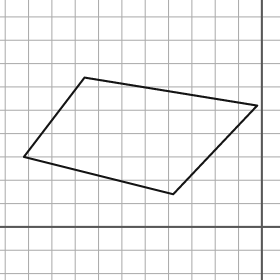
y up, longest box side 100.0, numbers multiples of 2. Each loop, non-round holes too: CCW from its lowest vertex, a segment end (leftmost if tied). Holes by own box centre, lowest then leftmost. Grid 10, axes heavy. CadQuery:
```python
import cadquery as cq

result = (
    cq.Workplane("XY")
    .moveTo(-38.0, 14.0)
    .lineTo(-2.0, 52.0)
    .lineTo(-76.0, 64.0)
    .lineTo(-102.0, 30.0)
    .close()
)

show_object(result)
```